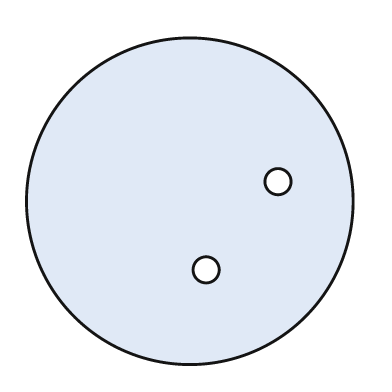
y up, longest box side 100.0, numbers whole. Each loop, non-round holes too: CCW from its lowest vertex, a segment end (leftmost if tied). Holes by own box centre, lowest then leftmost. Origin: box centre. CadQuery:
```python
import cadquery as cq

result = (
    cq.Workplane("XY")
    .moveTo(0.0, 0.0)
    .circle(50.0)
    .moveTo(5.0, -21.0)
    .circle(4.0)
    .moveTo(27.0, 6.0)
    .circle(4.0)
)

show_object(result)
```